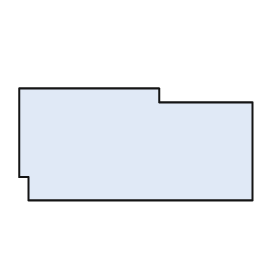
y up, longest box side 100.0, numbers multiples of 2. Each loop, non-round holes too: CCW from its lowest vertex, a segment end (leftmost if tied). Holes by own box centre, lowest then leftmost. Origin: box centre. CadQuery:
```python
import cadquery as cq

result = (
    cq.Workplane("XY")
    .moveTo(-46.0, -24.0)
    .lineTo(50.0, -24.0)
    .lineTo(50.0, 18.0)
    .lineTo(10.0, 18.0)
    .lineTo(10.0, 24.0)
    .lineTo(-50.0, 24.0)
    .lineTo(-50.0, -14.0)
    .lineTo(-46.0, -14.0)
    .close()
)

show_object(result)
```